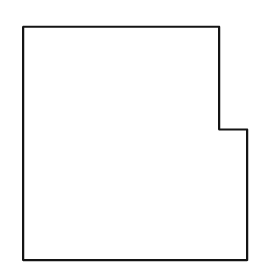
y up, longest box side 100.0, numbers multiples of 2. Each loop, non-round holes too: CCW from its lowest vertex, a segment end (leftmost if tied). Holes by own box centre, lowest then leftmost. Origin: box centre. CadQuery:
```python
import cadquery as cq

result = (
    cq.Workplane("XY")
    .moveTo(-48.0, -50.0)
    .lineTo(48.0, -50.0)
    .lineTo(48.0, 6.0)
    .lineTo(36.0, 6.0)
    .lineTo(36.0, 50.0)
    .lineTo(-48.0, 50.0)
    .close()
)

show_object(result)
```